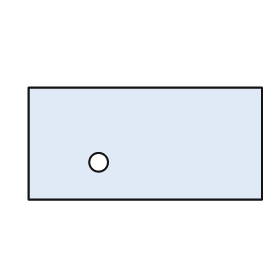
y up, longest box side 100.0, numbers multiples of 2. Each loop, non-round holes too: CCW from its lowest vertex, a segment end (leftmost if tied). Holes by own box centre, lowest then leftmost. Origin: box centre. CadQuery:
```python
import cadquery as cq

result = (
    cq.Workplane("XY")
    .moveTo(-50.0, -24.0)
    .lineTo(50.0, -24.0)
    .lineTo(50.0, 24.0)
    .lineTo(-50.0, 24.0)
    .close()
    .moveTo(-20.0, -8.0)
    .circle(4.0)
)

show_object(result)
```